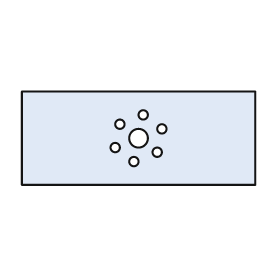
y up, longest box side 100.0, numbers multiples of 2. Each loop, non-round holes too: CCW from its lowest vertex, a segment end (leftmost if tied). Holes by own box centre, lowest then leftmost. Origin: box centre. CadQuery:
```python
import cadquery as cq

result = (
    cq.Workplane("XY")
    .moveTo(-50.0, -20.0)
    .lineTo(50.0, -20.0)
    .lineTo(50.0, 20.0)
    .lineTo(-50.0, 20.0)
    .close()
    .moveTo(-2.0, -10.0)
    .circle(2.0)
    .moveTo(8.0, -6.0)
    .circle(2.0)
    .moveTo(-10.0, -4.0)
    .circle(2.0)
    .moveTo(0.0, 0.0)
    .circle(4.0)
    .moveTo(10.0, 4.0)
    .circle(2.0)
    .moveTo(-8.0, 6.0)
    .circle(2.0)
    .moveTo(2.0, 10.0)
    .circle(2.0)
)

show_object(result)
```